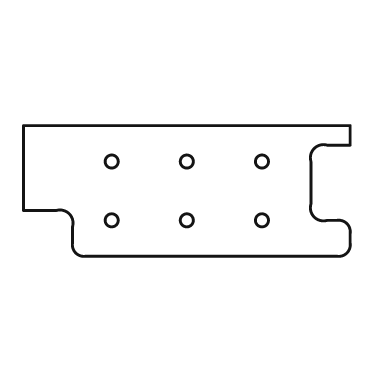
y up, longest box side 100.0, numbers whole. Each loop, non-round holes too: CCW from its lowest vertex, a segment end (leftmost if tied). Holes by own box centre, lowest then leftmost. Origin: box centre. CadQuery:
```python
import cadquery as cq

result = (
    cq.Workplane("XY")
    .moveTo(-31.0, -20.0)
    .lineTo(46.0, -20.0)
    .threePointArc((49.0, -19.0), (50.0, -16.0))
    .lineTo(50.0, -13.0)
    .threePointArc((49.0, -10.0), (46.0, -9.0))
    .lineTo(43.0, -9.0)
    .threePointArc((39.0, -8.0), (38.0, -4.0))
    .lineTo(38.0, 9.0)
    .threePointArc((39.0, 13.0), (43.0, 14.0))
    .lineTo(50.0, 14.0)
    .lineTo(50.0, 20.0)
    .lineTo(-50.0, 20.0)
    .lineTo(-50.0, -6.0)
    .lineTo(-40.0, -6.0)
    .threePointArc((-36.0, -7.0), (-35.0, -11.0))
    .lineTo(-35.0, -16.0)
    .threePointArc((-34.0, -19.0), (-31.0, -20.0))
    .close()
    .moveTo(-23.0, -9.0)
    .circle(2.0)
    .moveTo(0.0, -9.0)
    .circle(2.0)
    .moveTo(23.0, -9.0)
    .circle(2.0)
    .moveTo(-23.0, 9.0)
    .circle(2.0)
    .moveTo(0.0, 9.0)
    .circle(2.0)
    .moveTo(23.0, 9.0)
    .circle(2.0)
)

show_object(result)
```